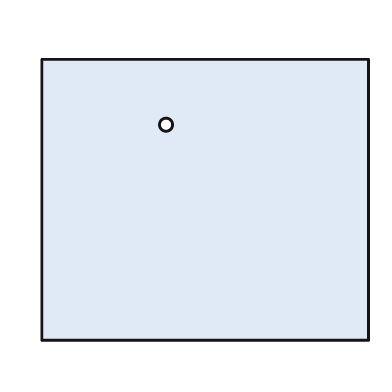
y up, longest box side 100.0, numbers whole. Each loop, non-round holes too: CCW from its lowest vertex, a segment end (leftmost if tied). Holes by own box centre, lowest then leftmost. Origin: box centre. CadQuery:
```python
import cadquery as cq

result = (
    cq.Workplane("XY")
    .moveTo(-50.0, -43.0)
    .lineTo(50.0, -43.0)
    .lineTo(50.0, 43.0)
    .lineTo(-50.0, 43.0)
    .close()
    .moveTo(-12.0, 23.0)
    .circle(2.0)
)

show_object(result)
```